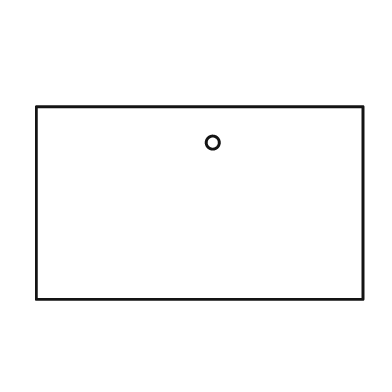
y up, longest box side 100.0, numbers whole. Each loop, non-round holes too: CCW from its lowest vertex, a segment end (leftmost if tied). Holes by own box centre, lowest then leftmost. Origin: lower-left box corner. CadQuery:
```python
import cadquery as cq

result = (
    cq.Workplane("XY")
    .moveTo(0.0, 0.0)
    .lineTo(100.0, 0.0)
    .lineTo(100.0, 59.0)
    .lineTo(0.0, 59.0)
    .close()
    .moveTo(54.0, 48.0)
    .circle(2.0)
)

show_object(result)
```